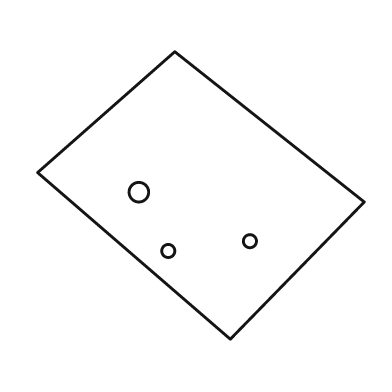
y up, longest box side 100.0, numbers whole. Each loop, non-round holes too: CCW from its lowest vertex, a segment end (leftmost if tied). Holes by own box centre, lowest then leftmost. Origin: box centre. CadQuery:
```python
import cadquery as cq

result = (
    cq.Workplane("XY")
    .moveTo(9.0, -44.0)
    .lineTo(50.0, -2.0)
    .lineTo(-8.0, 44.0)
    .lineTo(-50.0, 7.0)
    .close()
    .moveTo(-10.0, -17.0)
    .circle(2.0)
    .moveTo(15.0, -14.0)
    .circle(2.0)
    .moveTo(-19.0, 1.0)
    .circle(3.0)
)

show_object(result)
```